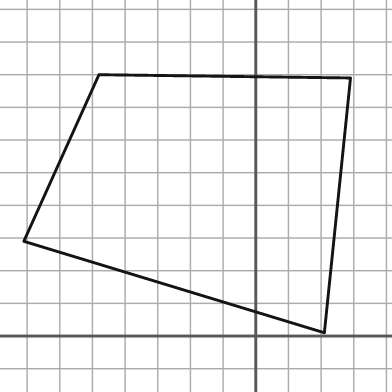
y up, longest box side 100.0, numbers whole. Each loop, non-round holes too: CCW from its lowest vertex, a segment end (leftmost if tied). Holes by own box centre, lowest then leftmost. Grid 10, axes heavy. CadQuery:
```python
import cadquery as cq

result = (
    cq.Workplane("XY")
    .moveTo(21.0, 1.0)
    .lineTo(29.0, 79.0)
    .lineTo(-48.0, 80.0)
    .lineTo(-71.0, 29.0)
    .close()
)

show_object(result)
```